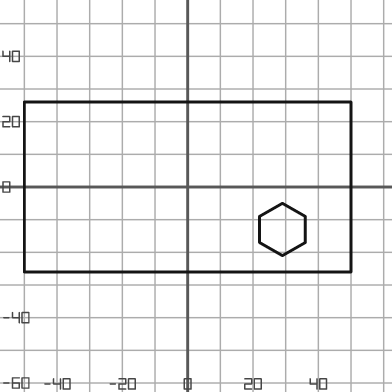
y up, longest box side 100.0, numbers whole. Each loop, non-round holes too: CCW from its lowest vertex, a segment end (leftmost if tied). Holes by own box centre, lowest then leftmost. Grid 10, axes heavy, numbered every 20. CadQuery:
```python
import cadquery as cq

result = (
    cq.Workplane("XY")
    .moveTo(-50.0, -26.0)
    .lineTo(50.0, -26.0)
    .lineTo(50.0, 26.0)
    .lineTo(-50.0, 26.0)
    .close()
    .moveTo(29.0, -21.0)
    .lineTo(36.0, -17.0)
    .lineTo(36.0, -9.0)
    .lineTo(29.0, -5.0)
    .lineTo(22.0, -9.0)
    .lineTo(22.0, -17.0)
    .close()
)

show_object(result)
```